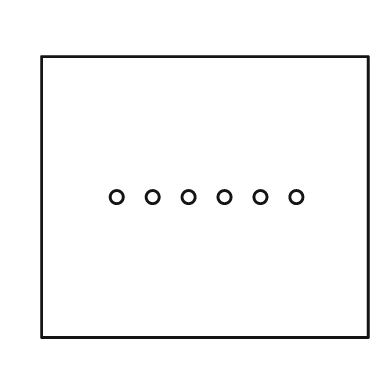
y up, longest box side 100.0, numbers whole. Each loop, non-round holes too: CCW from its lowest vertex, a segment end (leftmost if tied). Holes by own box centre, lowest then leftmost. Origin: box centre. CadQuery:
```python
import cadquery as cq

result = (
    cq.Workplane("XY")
    .moveTo(-50.0, -43.0)
    .lineTo(50.0, -43.0)
    .lineTo(50.0, 43.0)
    .lineTo(-50.0, 43.0)
    .close()
    .moveTo(-27.0, 0.0)
    .circle(2.0)
    .moveTo(-16.0, 0.0)
    .circle(2.0)
    .moveTo(-5.0, 0.0)
    .circle(2.0)
    .moveTo(6.0, 0.0)
    .circle(2.0)
    .moveTo(17.0, 0.0)
    .circle(2.0)
    .moveTo(28.0, 0.0)
    .circle(2.0)
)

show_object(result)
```